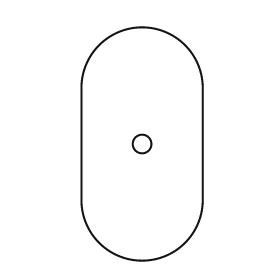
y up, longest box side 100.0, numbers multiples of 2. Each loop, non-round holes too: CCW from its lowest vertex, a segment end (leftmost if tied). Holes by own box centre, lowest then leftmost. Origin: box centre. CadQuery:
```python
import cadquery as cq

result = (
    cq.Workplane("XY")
    .moveTo(-26.0, -24.0)
    .threePointArc((0.0, -50.0), (26.0, -24.0))
    .lineTo(26.0, 24.0)
    .threePointArc((0.0, 50.0), (-26.0, 24.0))
    .close()
    .moveTo(0.0, 0.0)
    .circle(4.0)
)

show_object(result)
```